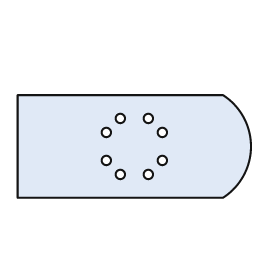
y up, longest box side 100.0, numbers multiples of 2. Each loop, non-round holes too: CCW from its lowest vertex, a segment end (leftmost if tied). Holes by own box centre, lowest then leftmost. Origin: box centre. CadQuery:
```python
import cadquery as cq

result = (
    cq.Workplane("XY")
    .moveTo(-50.0, -22.0)
    .lineTo(38.0, -22.0)
    .threePointArc((50.0, 0.0), (38.0, 22.0))
    .lineTo(-50.0, 22.0)
    .close()
    .moveTo(-6.0, -12.0)
    .circle(2.0)
    .moveTo(6.0, -12.0)
    .circle(2.0)
    .moveTo(-12.0, -6.0)
    .circle(2.0)
    .moveTo(12.0, -6.0)
    .circle(2.0)
    .moveTo(-12.0, 6.0)
    .circle(2.0)
    .moveTo(12.0, 6.0)
    .circle(2.0)
    .moveTo(-6.0, 12.0)
    .circle(2.0)
    .moveTo(6.0, 12.0)
    .circle(2.0)
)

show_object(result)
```